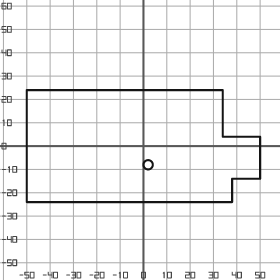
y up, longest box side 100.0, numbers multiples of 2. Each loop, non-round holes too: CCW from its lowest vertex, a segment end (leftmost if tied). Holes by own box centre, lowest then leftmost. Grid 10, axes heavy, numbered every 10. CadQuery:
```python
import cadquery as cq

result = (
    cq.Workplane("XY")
    .moveTo(-50.0, -24.0)
    .lineTo(38.0, -24.0)
    .lineTo(38.0, -14.0)
    .lineTo(50.0, -14.0)
    .lineTo(50.0, 4.0)
    .lineTo(34.0, 4.0)
    .lineTo(34.0, 24.0)
    .lineTo(-50.0, 24.0)
    .close()
    .moveTo(2.0, -8.0)
    .circle(2.0)
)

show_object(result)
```